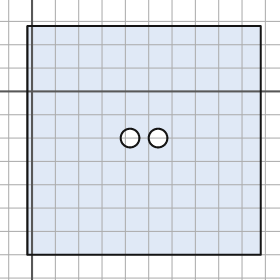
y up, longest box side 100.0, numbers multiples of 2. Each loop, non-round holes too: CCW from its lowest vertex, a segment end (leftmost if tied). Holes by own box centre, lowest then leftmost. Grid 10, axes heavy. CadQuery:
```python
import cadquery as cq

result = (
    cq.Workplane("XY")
    .moveTo(-2.0, -70.0)
    .lineTo(98.0, -70.0)
    .lineTo(98.0, 28.0)
    .lineTo(-2.0, 28.0)
    .close()
    .moveTo(42.0, -20.0)
    .circle(4.0)
    .moveTo(54.0, -20.0)
    .circle(4.0)
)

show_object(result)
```